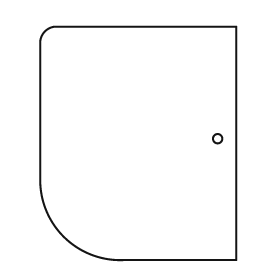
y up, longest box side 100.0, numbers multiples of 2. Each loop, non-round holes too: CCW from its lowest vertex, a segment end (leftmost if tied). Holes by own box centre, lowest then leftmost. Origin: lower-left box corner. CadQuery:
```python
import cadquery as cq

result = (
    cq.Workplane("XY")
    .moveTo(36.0, 0.0)
    .lineTo(84.0, 0.0)
    .lineTo(84.0, 100.0)
    .lineTo(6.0, 100.0)
    .threePointArc((2.0, 98.0), (0.0, 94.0))
    .lineTo(0.0, 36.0)
    .threePointArc((10.0, 10.0), (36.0, 0.0))
    .close()
    .moveTo(76.0, 52.0)
    .circle(2.0)
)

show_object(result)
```